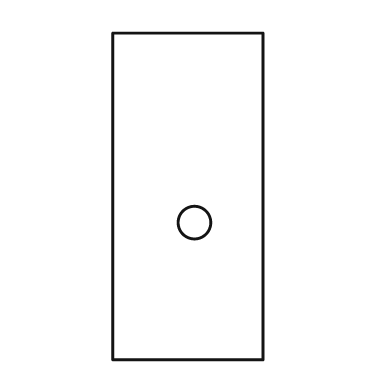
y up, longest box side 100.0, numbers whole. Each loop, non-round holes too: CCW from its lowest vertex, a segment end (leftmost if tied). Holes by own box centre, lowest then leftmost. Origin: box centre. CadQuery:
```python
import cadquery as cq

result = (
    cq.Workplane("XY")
    .moveTo(-23.0, -50.0)
    .lineTo(23.0, -50.0)
    .lineTo(23.0, 50.0)
    .lineTo(-23.0, 50.0)
    .close()
    .moveTo(2.0, -8.0)
    .circle(5.0)
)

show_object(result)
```